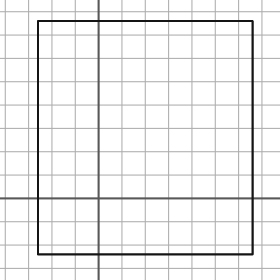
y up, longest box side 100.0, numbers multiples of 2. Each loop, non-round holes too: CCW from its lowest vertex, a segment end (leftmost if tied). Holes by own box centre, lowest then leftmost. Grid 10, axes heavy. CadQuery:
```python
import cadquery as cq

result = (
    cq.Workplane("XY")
    .moveTo(-26.0, -24.0)
    .lineTo(66.0, -24.0)
    .lineTo(66.0, 76.0)
    .lineTo(-26.0, 76.0)
    .close()
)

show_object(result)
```